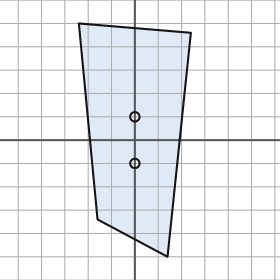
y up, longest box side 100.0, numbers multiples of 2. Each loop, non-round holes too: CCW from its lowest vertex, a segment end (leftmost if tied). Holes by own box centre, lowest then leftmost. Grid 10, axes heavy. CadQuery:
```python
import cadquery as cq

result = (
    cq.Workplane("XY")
    .moveTo(14.0, -50.0)
    .lineTo(24.0, 46.0)
    .lineTo(-24.0, 50.0)
    .lineTo(-16.0, -34.0)
    .close()
    .moveTo(0.0, -10.0)
    .circle(2.0)
    .moveTo(0.0, 10.0)
    .circle(2.0)
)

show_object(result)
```